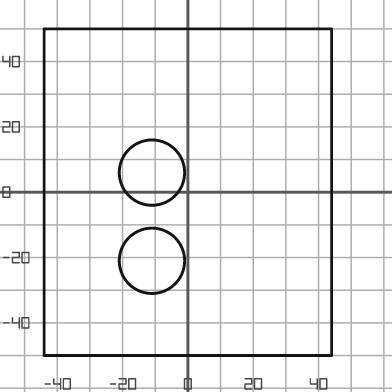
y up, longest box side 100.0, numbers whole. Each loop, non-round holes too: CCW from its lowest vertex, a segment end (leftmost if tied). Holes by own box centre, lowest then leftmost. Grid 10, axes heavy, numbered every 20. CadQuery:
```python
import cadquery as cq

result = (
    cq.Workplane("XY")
    .moveTo(-44.0, -50.0)
    .lineTo(44.0, -50.0)
    .lineTo(44.0, 50.0)
    .lineTo(-44.0, 50.0)
    .close()
    .moveTo(-11.0, -21.0)
    .circle(10.0)
    .moveTo(-11.0, 6.0)
    .circle(10.0)
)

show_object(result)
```